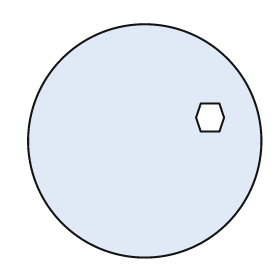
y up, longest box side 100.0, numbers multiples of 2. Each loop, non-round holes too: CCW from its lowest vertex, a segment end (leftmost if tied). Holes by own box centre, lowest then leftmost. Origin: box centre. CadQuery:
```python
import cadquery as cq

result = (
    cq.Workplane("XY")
    .moveTo(0.0, 0.0)
    .circle(50.0)
    .moveTo(24.0, 4.0)
    .lineTo(32.0, 4.0)
    .lineTo(34.0, 10.0)
    .lineTo(32.0, 16.0)
    .lineTo(24.0, 16.0)
    .lineTo(22.0, 10.0)
    .close()
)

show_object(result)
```